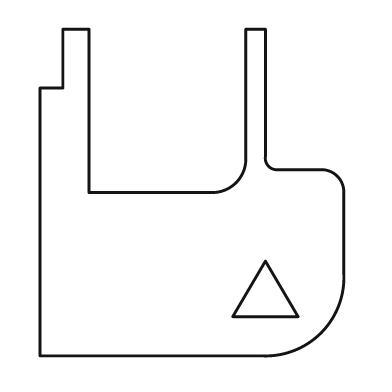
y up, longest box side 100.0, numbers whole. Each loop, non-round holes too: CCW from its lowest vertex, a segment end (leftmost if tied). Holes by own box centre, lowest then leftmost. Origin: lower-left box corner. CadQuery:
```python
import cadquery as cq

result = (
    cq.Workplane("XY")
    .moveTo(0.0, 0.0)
    .lineTo(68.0, 0.0)
    .threePointArc((86.0, 7.0), (93.0, 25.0))
    .lineTo(93.0, 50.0)
    .threePointArc((91.0, 55.0), (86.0, 57.0))
    .lineTo(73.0, 57.0)
    .threePointArc((70.0, 58.0), (69.0, 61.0))
    .lineTo(69.0, 100.0)
    .lineTo(63.0, 100.0)
    .lineTo(63.0, 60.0)
    .threePointArc((60.0, 53.0), (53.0, 50.0))
    .lineTo(15.0, 50.0)
    .lineTo(15.0, 100.0)
    .lineTo(7.0, 100.0)
    .lineTo(7.0, 82.0)
    .lineTo(0.0, 82.0)
    .close()
    .moveTo(59.0, 12.0)
    .lineTo(79.0, 12.0)
    .lineTo(69.0, 29.0)
    .close()
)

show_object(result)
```